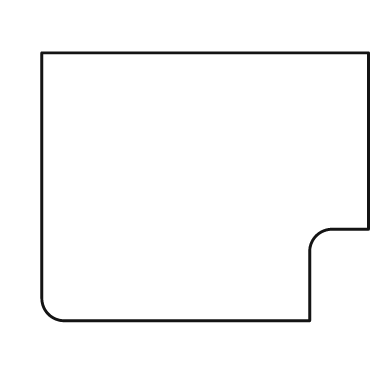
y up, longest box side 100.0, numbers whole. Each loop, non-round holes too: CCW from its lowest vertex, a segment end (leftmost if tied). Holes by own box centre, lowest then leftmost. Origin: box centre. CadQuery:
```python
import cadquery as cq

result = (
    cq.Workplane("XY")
    .moveTo(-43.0, -41.0)
    .lineTo(32.0, -41.0)
    .lineTo(32.0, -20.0)
    .threePointArc((34.0, -15.0), (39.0, -13.0))
    .lineTo(50.0, -13.0)
    .lineTo(50.0, 41.0)
    .lineTo(-50.0, 41.0)
    .lineTo(-50.0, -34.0)
    .threePointArc((-48.0, -39.0), (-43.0, -41.0))
    .close()
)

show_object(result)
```